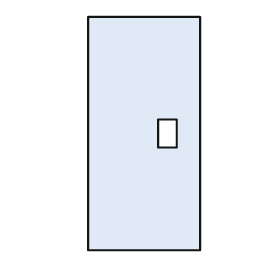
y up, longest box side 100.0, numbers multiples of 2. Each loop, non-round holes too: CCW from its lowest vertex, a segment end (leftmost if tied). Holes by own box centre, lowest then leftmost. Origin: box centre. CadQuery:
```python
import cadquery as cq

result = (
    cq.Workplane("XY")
    .moveTo(-24.0, -50.0)
    .lineTo(24.0, -50.0)
    .lineTo(24.0, 50.0)
    .lineTo(-24.0, 50.0)
    .close()
    .moveTo(6.0, -6.0)
    .lineTo(14.0, -6.0)
    .lineTo(14.0, 6.0)
    .lineTo(6.0, 6.0)
    .close()
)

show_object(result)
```